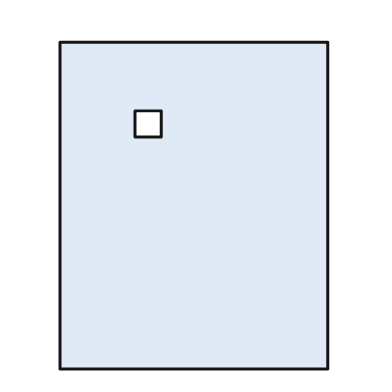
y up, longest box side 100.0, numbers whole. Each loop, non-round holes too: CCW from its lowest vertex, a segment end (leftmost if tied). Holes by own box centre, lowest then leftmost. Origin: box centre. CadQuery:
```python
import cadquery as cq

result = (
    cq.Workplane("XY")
    .moveTo(-41.0, -50.0)
    .lineTo(41.0, -50.0)
    .lineTo(41.0, 50.0)
    .lineTo(-41.0, 50.0)
    .close()
    .moveTo(-18.0, 21.0)
    .lineTo(-10.0, 21.0)
    .lineTo(-10.0, 29.0)
    .lineTo(-18.0, 29.0)
    .close()
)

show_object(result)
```